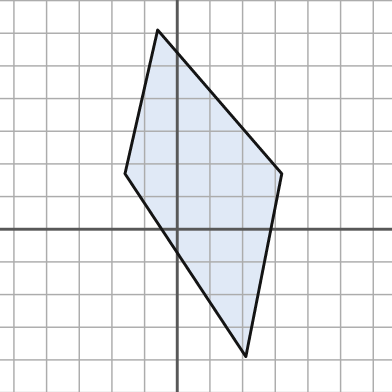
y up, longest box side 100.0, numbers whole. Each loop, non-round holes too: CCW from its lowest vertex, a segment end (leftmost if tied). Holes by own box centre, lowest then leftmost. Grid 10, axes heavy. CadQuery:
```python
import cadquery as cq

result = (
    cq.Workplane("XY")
    .moveTo(21.0, -39.0)
    .lineTo(32.0, 17.0)
    .lineTo(-6.0, 61.0)
    .lineTo(-16.0, 17.0)
    .close()
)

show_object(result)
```